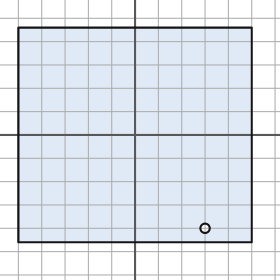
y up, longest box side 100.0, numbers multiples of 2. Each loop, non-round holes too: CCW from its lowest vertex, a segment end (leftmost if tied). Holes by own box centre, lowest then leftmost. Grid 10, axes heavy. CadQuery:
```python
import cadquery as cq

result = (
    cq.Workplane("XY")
    .moveTo(-50.0, -46.0)
    .lineTo(50.0, -46.0)
    .lineTo(50.0, 46.0)
    .lineTo(-50.0, 46.0)
    .close()
    .moveTo(30.0, -40.0)
    .circle(2.0)
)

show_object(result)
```